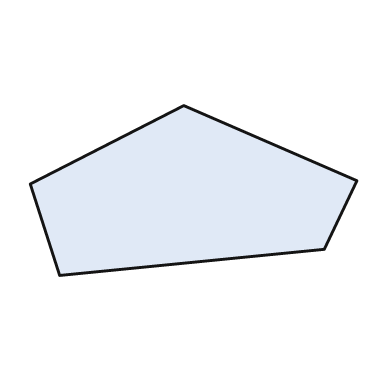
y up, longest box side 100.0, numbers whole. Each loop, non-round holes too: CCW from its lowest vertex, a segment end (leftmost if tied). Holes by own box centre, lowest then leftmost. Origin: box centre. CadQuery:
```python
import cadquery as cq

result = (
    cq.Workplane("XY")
    .moveTo(-41.0, -26.0)
    .lineTo(40.0, -18.0)
    .lineTo(50.0, 3.0)
    .lineTo(-3.0, 26.0)
    .lineTo(-50.0, 2.0)
    .close()
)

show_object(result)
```